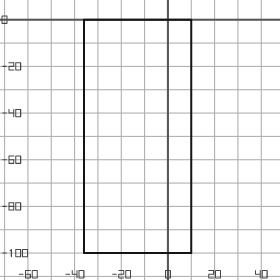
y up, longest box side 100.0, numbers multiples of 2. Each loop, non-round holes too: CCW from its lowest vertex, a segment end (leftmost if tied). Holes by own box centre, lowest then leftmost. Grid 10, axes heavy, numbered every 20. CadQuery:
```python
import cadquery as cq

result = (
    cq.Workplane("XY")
    .moveTo(-36.0, -100.0)
    .lineTo(10.0, -100.0)
    .lineTo(10.0, 0.0)
    .lineTo(-36.0, 0.0)
    .close()
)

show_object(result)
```